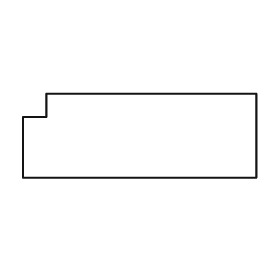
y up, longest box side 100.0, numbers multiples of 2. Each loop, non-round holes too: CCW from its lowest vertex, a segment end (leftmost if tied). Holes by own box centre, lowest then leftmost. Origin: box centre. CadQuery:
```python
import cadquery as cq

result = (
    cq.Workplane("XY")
    .moveTo(-50.0, -18.0)
    .lineTo(50.0, -18.0)
    .lineTo(50.0, 18.0)
    .lineTo(-40.0, 18.0)
    .lineTo(-40.0, 8.0)
    .lineTo(-50.0, 8.0)
    .close()
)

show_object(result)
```